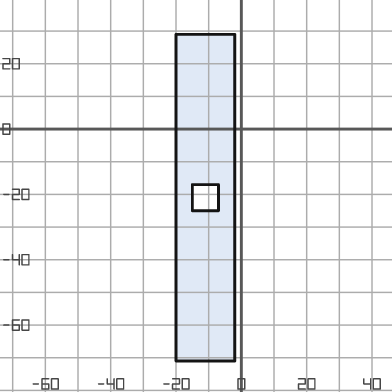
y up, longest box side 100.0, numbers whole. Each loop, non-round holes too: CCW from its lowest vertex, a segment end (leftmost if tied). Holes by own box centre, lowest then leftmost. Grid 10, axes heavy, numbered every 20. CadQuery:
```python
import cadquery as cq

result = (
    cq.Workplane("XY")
    .moveTo(-20.0, -71.0)
    .lineTo(-2.0, -71.0)
    .lineTo(-2.0, 29.0)
    .lineTo(-20.0, 29.0)
    .close()
    .moveTo(-15.0, -25.0)
    .lineTo(-7.0, -25.0)
    .lineTo(-7.0, -17.0)
    .lineTo(-15.0, -17.0)
    .close()
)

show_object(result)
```